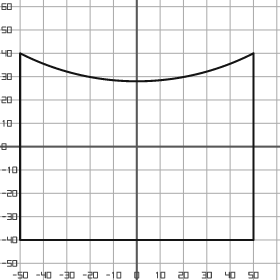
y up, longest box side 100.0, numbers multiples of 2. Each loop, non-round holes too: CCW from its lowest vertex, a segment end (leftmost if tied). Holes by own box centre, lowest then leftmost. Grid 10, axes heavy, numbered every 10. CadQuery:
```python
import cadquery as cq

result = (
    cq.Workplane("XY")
    .moveTo(-50.0, -40.0)
    .lineTo(50.0, -40.0)
    .lineTo(50.0, 40.0)
    .threePointArc((0.0, 28.0), (-50.0, 40.0))
    .close()
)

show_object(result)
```